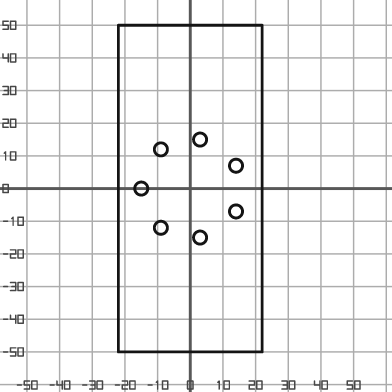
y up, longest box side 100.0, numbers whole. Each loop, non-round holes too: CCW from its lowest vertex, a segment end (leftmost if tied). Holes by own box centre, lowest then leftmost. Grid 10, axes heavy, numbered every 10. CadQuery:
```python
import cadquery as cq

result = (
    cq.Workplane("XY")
    .moveTo(-22.0, -50.0)
    .lineTo(22.0, -50.0)
    .lineTo(22.0, 50.0)
    .lineTo(-22.0, 50.0)
    .close()
    .moveTo(3.0, -15.0)
    .circle(2.0)
    .moveTo(-9.0, -12.0)
    .circle(2.0)
    .moveTo(14.0, -7.0)
    .circle(2.0)
    .moveTo(-15.0, 0.0)
    .circle(2.0)
    .moveTo(14.0, 7.0)
    .circle(2.0)
    .moveTo(-9.0, 12.0)
    .circle(2.0)
    .moveTo(3.0, 15.0)
    .circle(2.0)
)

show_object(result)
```